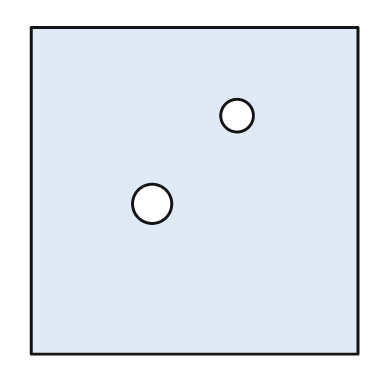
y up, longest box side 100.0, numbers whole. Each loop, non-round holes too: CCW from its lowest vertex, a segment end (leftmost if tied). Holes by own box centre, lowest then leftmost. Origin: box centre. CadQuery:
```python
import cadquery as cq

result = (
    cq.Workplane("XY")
    .moveTo(-50.0, -50.0)
    .lineTo(50.0, -50.0)
    .lineTo(50.0, 50.0)
    .lineTo(-50.0, 50.0)
    .close()
    .moveTo(-13.0, -4.0)
    .circle(6.0)
    .moveTo(13.0, 23.0)
    .circle(5.0)
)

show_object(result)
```